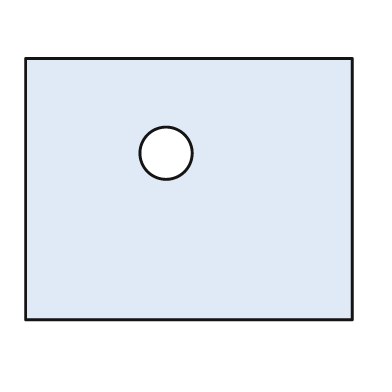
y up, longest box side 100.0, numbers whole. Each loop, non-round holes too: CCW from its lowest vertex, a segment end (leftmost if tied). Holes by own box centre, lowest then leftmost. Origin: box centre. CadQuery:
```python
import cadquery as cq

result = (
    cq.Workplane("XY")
    .moveTo(-50.0, -40.0)
    .lineTo(50.0, -40.0)
    .lineTo(50.0, 40.0)
    .lineTo(-50.0, 40.0)
    .close()
    .moveTo(-7.0, 11.0)
    .circle(8.0)
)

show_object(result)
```